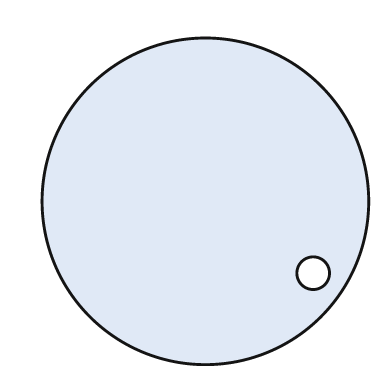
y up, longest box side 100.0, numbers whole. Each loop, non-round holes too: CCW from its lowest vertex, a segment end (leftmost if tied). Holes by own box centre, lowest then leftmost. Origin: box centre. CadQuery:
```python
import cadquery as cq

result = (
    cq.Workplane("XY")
    .moveTo(0.0, 0.0)
    .circle(50.0)
    .moveTo(33.0, -22.0)
    .circle(5.0)
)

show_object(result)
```